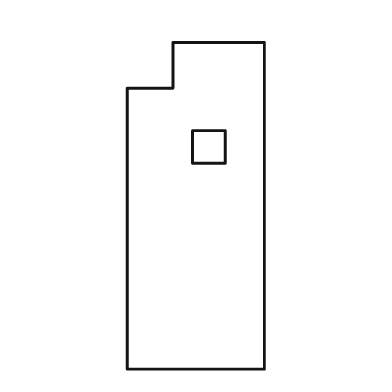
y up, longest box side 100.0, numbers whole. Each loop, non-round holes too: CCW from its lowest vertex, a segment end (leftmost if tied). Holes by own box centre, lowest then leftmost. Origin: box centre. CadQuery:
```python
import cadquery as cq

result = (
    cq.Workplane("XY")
    .moveTo(-21.0, -50.0)
    .lineTo(21.0, -50.0)
    .lineTo(21.0, 50.0)
    .lineTo(-7.0, 50.0)
    .lineTo(-7.0, 36.0)
    .lineTo(-21.0, 36.0)
    .close()
    .moveTo(-1.0, 13.0)
    .lineTo(9.0, 13.0)
    .lineTo(9.0, 23.0)
    .lineTo(-1.0, 23.0)
    .close()
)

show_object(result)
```